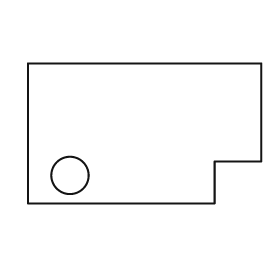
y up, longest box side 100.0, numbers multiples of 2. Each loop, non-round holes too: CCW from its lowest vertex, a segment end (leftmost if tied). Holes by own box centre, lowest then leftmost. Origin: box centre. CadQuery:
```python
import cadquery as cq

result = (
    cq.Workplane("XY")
    .moveTo(-50.0, -30.0)
    .lineTo(30.0, -30.0)
    .lineTo(30.0, -12.0)
    .lineTo(50.0, -12.0)
    .lineTo(50.0, 30.0)
    .lineTo(-50.0, 30.0)
    .close()
    .moveTo(-32.0, -18.0)
    .circle(8.0)
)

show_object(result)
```